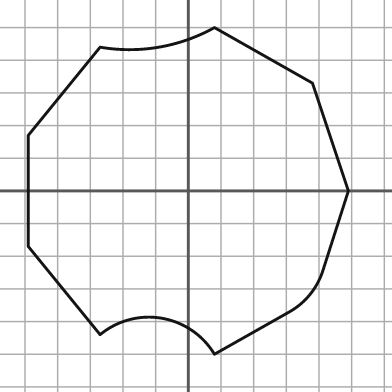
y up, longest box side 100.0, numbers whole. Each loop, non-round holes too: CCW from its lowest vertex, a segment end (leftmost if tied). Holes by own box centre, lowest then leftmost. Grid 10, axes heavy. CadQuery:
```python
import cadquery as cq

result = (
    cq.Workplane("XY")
    .moveTo(8.0, -50.0)
    .lineTo(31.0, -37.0)
    .threePointArc((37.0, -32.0), (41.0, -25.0))
    .lineTo(49.0, 0.0)
    .lineTo(38.0, 33.0)
    .lineTo(8.0, 50.0)
    .threePointArc((-9.0, 44.0), (-27.0, 44.0))
    .lineTo(-49.0, 17.0)
    .lineTo(-49.0, -17.0)
    .lineTo(-27.0, -44.0)
    .threePointArc((-8.0, -39.0), (8.0, -50.0))
    .close()
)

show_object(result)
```